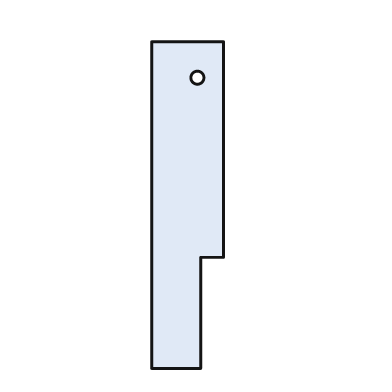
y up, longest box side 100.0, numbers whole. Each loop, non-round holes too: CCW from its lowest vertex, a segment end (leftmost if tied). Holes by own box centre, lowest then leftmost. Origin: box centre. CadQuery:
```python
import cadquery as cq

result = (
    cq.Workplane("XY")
    .moveTo(-11.0, -50.0)
    .lineTo(4.0, -50.0)
    .lineTo(4.0, -16.0)
    .lineTo(11.0, -16.0)
    .lineTo(11.0, 50.0)
    .lineTo(-11.0, 50.0)
    .close()
    .moveTo(3.0, 39.0)
    .circle(2.0)
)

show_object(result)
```